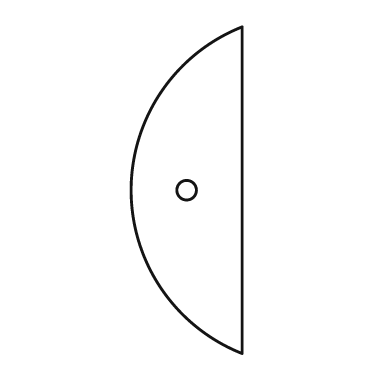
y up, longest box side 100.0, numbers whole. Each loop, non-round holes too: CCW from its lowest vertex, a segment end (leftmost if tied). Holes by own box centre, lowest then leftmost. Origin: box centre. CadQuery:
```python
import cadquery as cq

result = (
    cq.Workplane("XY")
    .moveTo(17.0, -50.0)
    .lineTo(17.0, 50.0)
    .threePointArc((-17.0, 0.0), (17.0, -50.0))
    .close()
    .moveTo(0.0, 0.0)
    .circle(3.0)
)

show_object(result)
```